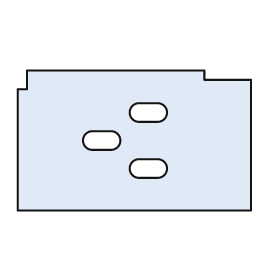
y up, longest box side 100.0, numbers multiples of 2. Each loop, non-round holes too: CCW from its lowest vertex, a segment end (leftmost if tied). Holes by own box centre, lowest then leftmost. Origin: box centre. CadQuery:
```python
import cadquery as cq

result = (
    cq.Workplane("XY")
    .moveTo(-50.0, -30.0)
    .lineTo(50.0, -30.0)
    .lineTo(50.0, 26.0)
    .lineTo(30.0, 26.0)
    .lineTo(30.0, 30.0)
    .lineTo(-46.0, 30.0)
    .lineTo(-46.0, 22.0)
    .lineTo(-50.0, 22.0)
    .close()
    .moveTo(2.0, -16.0)
    .lineTo(10.0, -16.0)
    .threePointArc((14.0, -12.0), (10.0, -8.0))
    .lineTo(2.0, -8.0)
    .threePointArc((-2.0, -12.0), (2.0, -16.0))
    .close()
    .moveTo(-18.0, -4.0)
    .lineTo(-10.0, -4.0)
    .threePointArc((-6.0, 0.0), (-10.0, 4.0))
    .lineTo(-18.0, 4.0)
    .threePointArc((-22.0, 0.0), (-18.0, -4.0))
    .close()
    .moveTo(2.0, 8.0)
    .lineTo(10.0, 8.0)
    .threePointArc((14.0, 12.0), (10.0, 16.0))
    .lineTo(2.0, 16.0)
    .threePointArc((-2.0, 12.0), (2.0, 8.0))
    .close()
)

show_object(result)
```